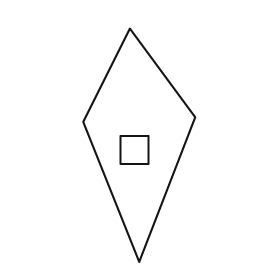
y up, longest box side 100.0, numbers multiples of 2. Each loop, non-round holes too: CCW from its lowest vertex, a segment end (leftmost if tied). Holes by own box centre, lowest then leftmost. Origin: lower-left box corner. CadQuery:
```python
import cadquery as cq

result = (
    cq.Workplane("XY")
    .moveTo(24.0, 0.0)
    .lineTo(48.0, 62.0)
    .lineTo(20.0, 100.0)
    .lineTo(0.0, 60.0)
    .close()
    .moveTo(16.0, 42.0)
    .lineTo(28.0, 42.0)
    .lineTo(28.0, 54.0)
    .lineTo(16.0, 54.0)
    .close()
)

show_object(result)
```